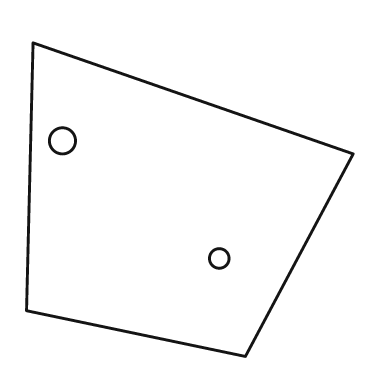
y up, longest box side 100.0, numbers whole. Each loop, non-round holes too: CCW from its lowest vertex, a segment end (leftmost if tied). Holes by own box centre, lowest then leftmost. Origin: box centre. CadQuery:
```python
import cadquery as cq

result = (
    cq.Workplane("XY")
    .moveTo(17.0, -48.0)
    .lineTo(50.0, 14.0)
    .lineTo(-48.0, 48.0)
    .lineTo(-50.0, -34.0)
    .close()
    .moveTo(9.0, -18.0)
    .circle(3.0)
    .moveTo(-39.0, 18.0)
    .circle(4.0)
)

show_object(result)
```